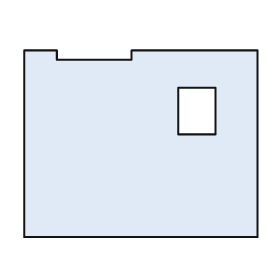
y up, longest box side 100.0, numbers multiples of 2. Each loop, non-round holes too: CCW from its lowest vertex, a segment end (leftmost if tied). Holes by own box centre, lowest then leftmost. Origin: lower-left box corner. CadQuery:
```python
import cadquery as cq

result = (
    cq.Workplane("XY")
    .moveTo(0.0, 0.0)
    .lineTo(100.0, 0.0)
    .lineTo(100.0, 80.0)
    .lineTo(46.0, 80.0)
    .lineTo(46.0, 76.0)
    .lineTo(14.0, 76.0)
    .lineTo(14.0, 80.0)
    .lineTo(0.0, 80.0)
    .close()
    .moveTo(66.0, 44.0)
    .lineTo(82.0, 44.0)
    .lineTo(82.0, 64.0)
    .lineTo(66.0, 64.0)
    .close()
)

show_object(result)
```